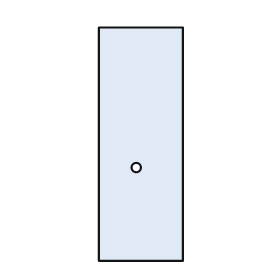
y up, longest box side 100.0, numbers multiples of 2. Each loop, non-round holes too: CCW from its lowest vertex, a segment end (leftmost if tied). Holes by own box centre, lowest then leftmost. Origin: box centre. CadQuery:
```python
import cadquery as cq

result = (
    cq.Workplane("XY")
    .moveTo(-18.0, -50.0)
    .lineTo(18.0, -50.0)
    .lineTo(18.0, 50.0)
    .lineTo(-18.0, 50.0)
    .close()
    .moveTo(-2.0, -10.0)
    .circle(2.0)
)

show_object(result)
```